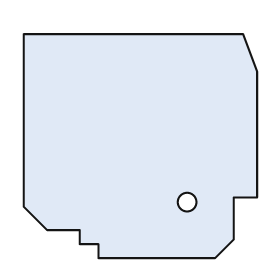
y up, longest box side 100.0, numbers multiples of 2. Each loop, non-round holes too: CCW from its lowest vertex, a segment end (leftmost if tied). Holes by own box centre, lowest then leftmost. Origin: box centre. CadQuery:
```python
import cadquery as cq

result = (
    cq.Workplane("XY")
    .moveTo(-18.0, -48.0)
    .lineTo(32.0, -48.0)
    .lineTo(40.0, -40.0)
    .lineTo(40.0, -22.0)
    .lineTo(50.0, -22.0)
    .lineTo(50.0, 32.0)
    .lineTo(44.0, 48.0)
    .lineTo(-50.0, 48.0)
    .lineTo(-50.0, -26.0)
    .lineTo(-40.0, -36.0)
    .lineTo(-26.0, -36.0)
    .lineTo(-26.0, -42.0)
    .lineTo(-18.0, -42.0)
    .close()
    .moveTo(20.0, -24.0)
    .circle(4.0)
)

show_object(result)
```